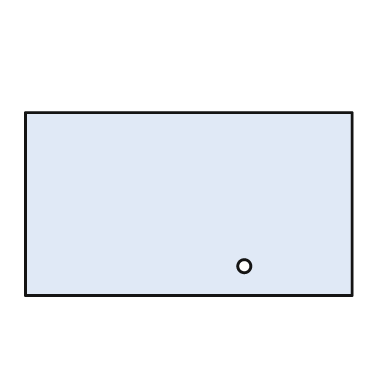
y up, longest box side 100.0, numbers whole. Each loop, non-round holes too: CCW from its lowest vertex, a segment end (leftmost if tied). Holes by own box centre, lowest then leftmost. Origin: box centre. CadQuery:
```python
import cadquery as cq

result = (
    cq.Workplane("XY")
    .moveTo(-50.0, -28.0)
    .lineTo(50.0, -28.0)
    .lineTo(50.0, 28.0)
    .lineTo(-50.0, 28.0)
    .close()
    .moveTo(17.0, -19.0)
    .circle(2.0)
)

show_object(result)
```